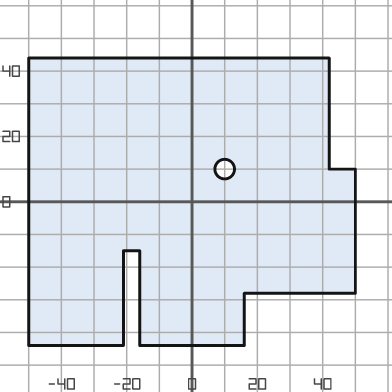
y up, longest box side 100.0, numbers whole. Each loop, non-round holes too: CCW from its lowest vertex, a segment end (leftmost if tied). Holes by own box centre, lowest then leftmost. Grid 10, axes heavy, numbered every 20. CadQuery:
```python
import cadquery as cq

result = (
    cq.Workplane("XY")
    .moveTo(-50.0, -44.0)
    .lineTo(-21.0, -44.0)
    .lineTo(-21.0, -15.0)
    .lineTo(-16.0, -15.0)
    .lineTo(-16.0, -44.0)
    .lineTo(16.0, -44.0)
    .lineTo(16.0, -28.0)
    .lineTo(50.0, -28.0)
    .lineTo(50.0, 10.0)
    .lineTo(42.0, 10.0)
    .lineTo(42.0, 44.0)
    .lineTo(-50.0, 44.0)
    .close()
    .moveTo(10.0, 10.0)
    .circle(3.0)
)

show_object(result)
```